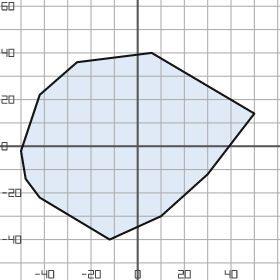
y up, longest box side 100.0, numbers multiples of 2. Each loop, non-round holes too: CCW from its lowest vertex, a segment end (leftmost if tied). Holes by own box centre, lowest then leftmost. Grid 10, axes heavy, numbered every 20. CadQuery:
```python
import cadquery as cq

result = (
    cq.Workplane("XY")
    .moveTo(-12.0, -40.0)
    .lineTo(10.0, -30.0)
    .lineTo(30.0, -12.0)
    .lineTo(50.0, 14.0)
    .lineTo(6.0, 40.0)
    .lineTo(-26.0, 36.0)
    .lineTo(-42.0, 22.0)
    .lineTo(-50.0, -2.0)
    .lineTo(-48.0, -14.0)
    .lineTo(-42.0, -22.0)
    .close()
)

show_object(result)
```